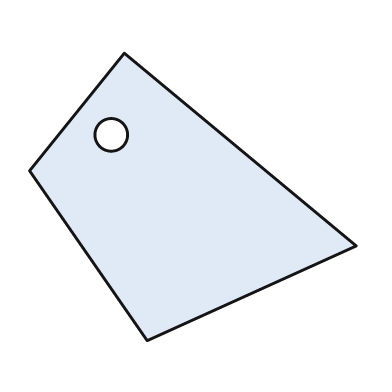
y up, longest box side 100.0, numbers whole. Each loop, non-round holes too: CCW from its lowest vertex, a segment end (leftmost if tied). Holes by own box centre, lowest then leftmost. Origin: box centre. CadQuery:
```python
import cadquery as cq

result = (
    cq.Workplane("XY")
    .moveTo(-14.0, -44.0)
    .lineTo(50.0, -15.0)
    .lineTo(-21.0, 44.0)
    .lineTo(-50.0, 8.0)
    .close()
    .moveTo(-25.0, 19.0)
    .circle(5.0)
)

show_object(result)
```